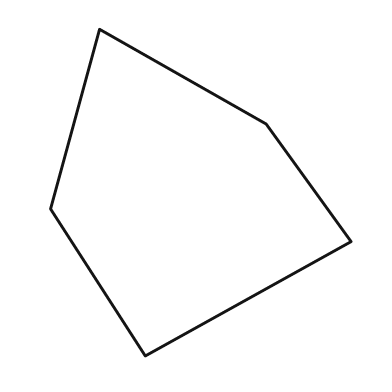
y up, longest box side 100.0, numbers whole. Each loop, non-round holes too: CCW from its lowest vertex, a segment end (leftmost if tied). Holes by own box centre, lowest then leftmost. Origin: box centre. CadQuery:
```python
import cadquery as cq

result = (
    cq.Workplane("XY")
    .moveTo(-17.0, -50.0)
    .lineTo(46.0, -15.0)
    .lineTo(20.0, 21.0)
    .lineTo(-31.0, 50.0)
    .lineTo(-46.0, -5.0)
    .close()
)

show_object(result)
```